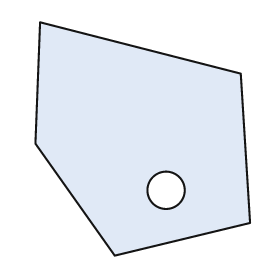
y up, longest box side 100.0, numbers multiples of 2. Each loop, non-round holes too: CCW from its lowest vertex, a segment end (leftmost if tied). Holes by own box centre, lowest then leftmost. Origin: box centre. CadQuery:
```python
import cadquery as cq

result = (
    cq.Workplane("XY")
    .moveTo(-12.0, -50.0)
    .lineTo(46.0, -36.0)
    .lineTo(42.0, 28.0)
    .lineTo(-44.0, 50.0)
    .lineTo(-46.0, -2.0)
    .close()
    .moveTo(10.0, -22.0)
    .circle(8.0)
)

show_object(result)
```